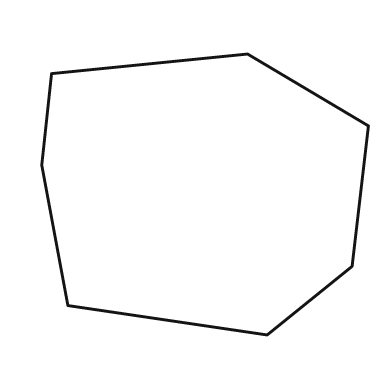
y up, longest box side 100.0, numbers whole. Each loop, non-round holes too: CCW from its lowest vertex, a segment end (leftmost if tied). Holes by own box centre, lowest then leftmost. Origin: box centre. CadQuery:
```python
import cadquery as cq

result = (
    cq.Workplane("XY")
    .moveTo(19.0, -43.0)
    .lineTo(45.0, -22.0)
    .lineTo(50.0, 21.0)
    .lineTo(13.0, 43.0)
    .lineTo(-47.0, 37.0)
    .lineTo(-50.0, 9.0)
    .lineTo(-42.0, -34.0)
    .close()
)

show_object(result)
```